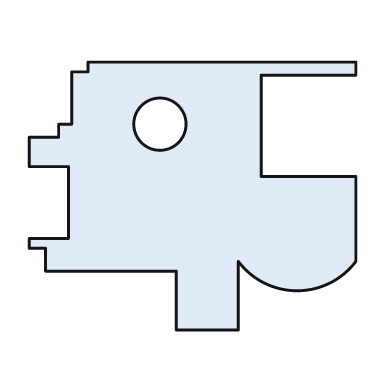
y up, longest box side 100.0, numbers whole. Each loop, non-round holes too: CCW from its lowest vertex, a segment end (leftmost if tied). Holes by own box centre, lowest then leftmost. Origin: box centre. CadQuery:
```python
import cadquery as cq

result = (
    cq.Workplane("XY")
    .moveTo(-5.0, -41.0)
    .lineTo(14.0, -41.0)
    .lineTo(14.0, -20.0)
    .threePointArc((32.0, -29.0), (50.0, -20.0))
    .lineTo(50.0, 6.0)
    .lineTo(21.0, 6.0)
    .lineTo(21.0, 37.0)
    .lineTo(50.0, 37.0)
    .lineTo(50.0, 41.0)
    .lineTo(-32.0, 41.0)
    .lineTo(-32.0, 38.0)
    .lineTo(-37.0, 38.0)
    .lineTo(-37.0, 22.0)
    .lineTo(-41.0, 22.0)
    .lineTo(-41.0, 18.0)
    .lineTo(-50.0, 18.0)
    .lineTo(-50.0, 9.0)
    .lineTo(-38.0, 9.0)
    .lineTo(-38.0, -13.0)
    .lineTo(-50.0, -13.0)
    .lineTo(-50.0, -16.0)
    .lineTo(-45.0, -16.0)
    .lineTo(-45.0, -23.0)
    .lineTo(-5.0, -23.0)
    .close()
    .moveTo(-10.0, 22.0)
    .circle(8.0)
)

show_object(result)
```